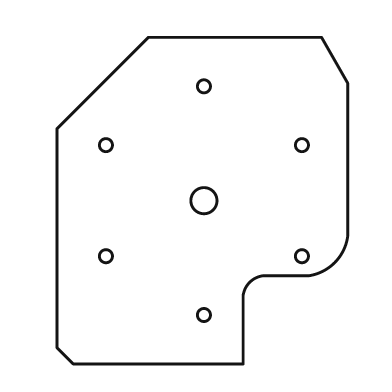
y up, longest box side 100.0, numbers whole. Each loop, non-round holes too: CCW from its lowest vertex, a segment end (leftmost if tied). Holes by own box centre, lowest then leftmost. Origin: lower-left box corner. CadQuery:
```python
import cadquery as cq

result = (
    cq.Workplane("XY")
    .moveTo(5.0, 0.0)
    .lineTo(57.0, 0.0)
    .lineTo(57.0, 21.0)
    .threePointArc((59.0, 25.0), (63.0, 27.0))
    .lineTo(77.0, 27.0)
    .threePointArc((85.0, 31.0), (89.0, 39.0))
    .lineTo(89.0, 86.0)
    .lineTo(81.0, 100.0)
    .lineTo(28.0, 100.0)
    .lineTo(0.0, 72.0)
    .lineTo(0.0, 5.0)
    .close()
    .moveTo(45.0, 15.0)
    .circle(2.0)
    .moveTo(15.0, 33.0)
    .circle(2.0)
    .moveTo(75.0, 33.0)
    .circle(2.0)
    .moveTo(45.0, 50.0)
    .circle(4.0)
    .moveTo(15.0, 67.0)
    .circle(2.0)
    .moveTo(75.0, 67.0)
    .circle(2.0)
    .moveTo(45.0, 85.0)
    .circle(2.0)
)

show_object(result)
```